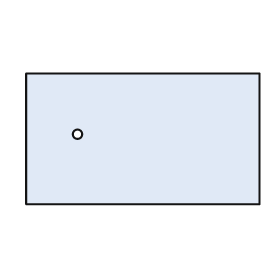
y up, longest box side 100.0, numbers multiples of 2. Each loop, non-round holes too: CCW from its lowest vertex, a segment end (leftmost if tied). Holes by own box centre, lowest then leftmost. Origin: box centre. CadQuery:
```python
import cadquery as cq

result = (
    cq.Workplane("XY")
    .moveTo(-50.0, -28.0)
    .lineTo(50.0, -28.0)
    .lineTo(50.0, 28.0)
    .lineTo(-50.0, 28.0)
    .close()
    .moveTo(-28.0, 2.0)
    .circle(2.0)
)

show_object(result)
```